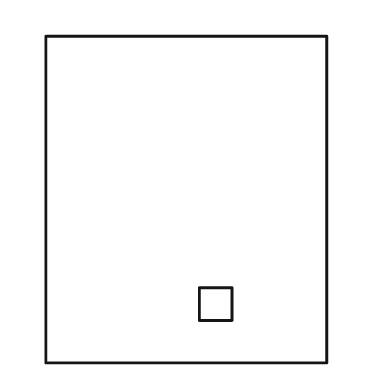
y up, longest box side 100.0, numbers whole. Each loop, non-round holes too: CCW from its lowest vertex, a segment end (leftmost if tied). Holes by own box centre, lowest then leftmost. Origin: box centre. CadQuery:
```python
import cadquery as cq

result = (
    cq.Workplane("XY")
    .moveTo(-43.0, -50.0)
    .lineTo(43.0, -50.0)
    .lineTo(43.0, 50.0)
    .lineTo(-43.0, 50.0)
    .close()
    .moveTo(4.0, -37.0)
    .lineTo(14.0, -37.0)
    .lineTo(14.0, -27.0)
    .lineTo(4.0, -27.0)
    .close()
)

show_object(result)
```